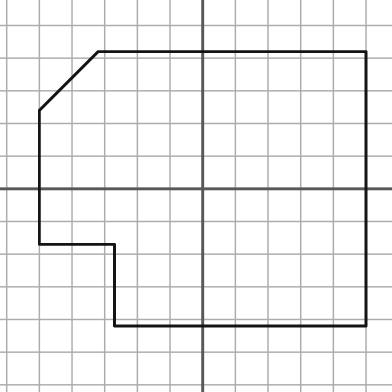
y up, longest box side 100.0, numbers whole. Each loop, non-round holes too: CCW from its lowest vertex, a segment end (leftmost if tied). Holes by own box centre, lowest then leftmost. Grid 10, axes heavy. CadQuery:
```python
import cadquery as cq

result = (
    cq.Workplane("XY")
    .moveTo(-27.0, -42.0)
    .lineTo(50.0, -42.0)
    .lineTo(50.0, 42.0)
    .lineTo(-32.0, 42.0)
    .lineTo(-50.0, 24.0)
    .lineTo(-50.0, -17.0)
    .lineTo(-27.0, -17.0)
    .close()
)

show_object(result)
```